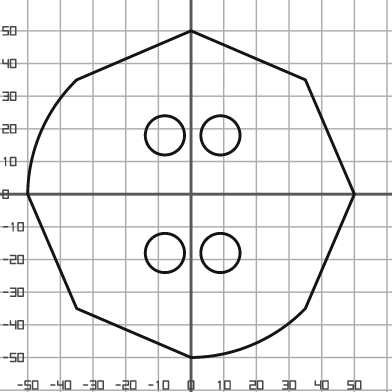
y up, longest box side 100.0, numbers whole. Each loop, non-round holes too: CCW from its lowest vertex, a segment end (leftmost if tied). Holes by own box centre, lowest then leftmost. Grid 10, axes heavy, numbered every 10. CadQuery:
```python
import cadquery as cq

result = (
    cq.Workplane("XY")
    .moveTo(0.0, -50.0)
    .threePointArc((19.0, -46.0), (35.0, -35.0))
    .lineTo(50.0, 0.0)
    .lineTo(35.0, 35.0)
    .lineTo(0.0, 50.0)
    .lineTo(-35.0, 35.0)
    .threePointArc((-46.0, 19.0), (-50.0, 0.0))
    .lineTo(-35.0, -35.0)
    .close()
    .moveTo(-8.0, -18.0)
    .circle(6.0)
    .moveTo(9.0, -18.0)
    .circle(6.0)
    .moveTo(-8.0, 18.0)
    .circle(6.0)
    .moveTo(9.0, 18.0)
    .circle(6.0)
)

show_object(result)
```